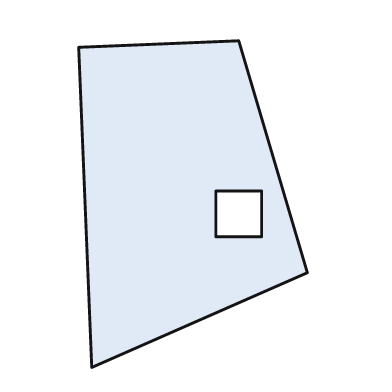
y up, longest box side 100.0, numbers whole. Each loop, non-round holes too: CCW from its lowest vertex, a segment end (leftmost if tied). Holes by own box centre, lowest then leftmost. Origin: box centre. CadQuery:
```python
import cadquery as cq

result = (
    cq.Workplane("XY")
    .moveTo(-31.0, -50.0)
    .lineTo(35.0, -21.0)
    .lineTo(14.0, 50.0)
    .lineTo(-35.0, 48.0)
    .close()
    .moveTo(7.0, -10.0)
    .lineTo(21.0, -10.0)
    .lineTo(21.0, 4.0)
    .lineTo(7.0, 4.0)
    .close()
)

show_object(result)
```